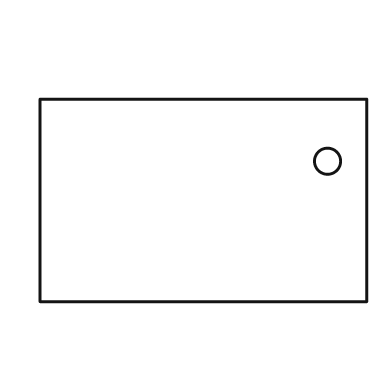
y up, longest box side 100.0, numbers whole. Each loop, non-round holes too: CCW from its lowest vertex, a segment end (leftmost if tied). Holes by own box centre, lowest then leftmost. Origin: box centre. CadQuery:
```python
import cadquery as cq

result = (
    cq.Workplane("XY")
    .moveTo(-50.0, -31.0)
    .lineTo(50.0, -31.0)
    .lineTo(50.0, 31.0)
    .lineTo(-50.0, 31.0)
    .close()
    .moveTo(38.0, 12.0)
    .circle(4.0)
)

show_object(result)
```